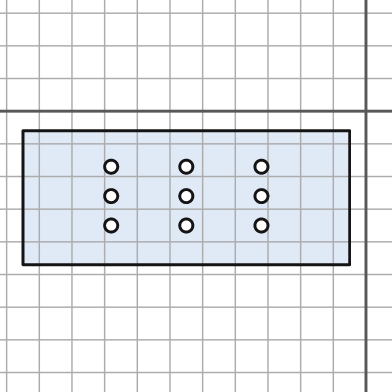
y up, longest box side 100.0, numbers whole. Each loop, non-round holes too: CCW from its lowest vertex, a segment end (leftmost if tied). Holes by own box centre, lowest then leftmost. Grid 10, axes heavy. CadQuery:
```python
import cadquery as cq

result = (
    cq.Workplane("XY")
    .moveTo(-105.0, -47.0)
    .lineTo(-5.0, -47.0)
    .lineTo(-5.0, -6.0)
    .lineTo(-105.0, -6.0)
    .close()
    .moveTo(-78.0, -35.0)
    .circle(2.0)
    .moveTo(-55.0, -35.0)
    .circle(2.0)
    .moveTo(-32.0, -35.0)
    .circle(2.0)
    .moveTo(-78.0, -26.0)
    .circle(2.0)
    .moveTo(-55.0, -26.0)
    .circle(2.0)
    .moveTo(-32.0, -26.0)
    .circle(2.0)
    .moveTo(-78.0, -17.0)
    .circle(2.0)
    .moveTo(-55.0, -17.0)
    .circle(2.0)
    .moveTo(-32.0, -17.0)
    .circle(2.0)
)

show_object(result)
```